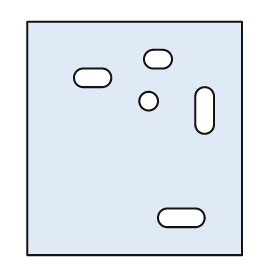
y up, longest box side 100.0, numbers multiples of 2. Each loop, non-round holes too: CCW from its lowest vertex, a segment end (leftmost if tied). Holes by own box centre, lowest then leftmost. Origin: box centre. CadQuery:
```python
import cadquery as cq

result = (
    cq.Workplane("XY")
    .moveTo(-46.0, -50.0)
    .lineTo(46.0, -50.0)
    .lineTo(46.0, 50.0)
    .lineTo(-46.0, 50.0)
    .close()
    .moveTo(14.0, -38.0)
    .lineTo(26.0, -38.0)
    .threePointArc((30.0, -34.0), (26.0, -30.0))
    .lineTo(14.0, -30.0)
    .threePointArc((10.0, -34.0), (14.0, -38.0))
    .close()
    .moveTo(26.0, 6.0)
    .threePointArc((30.0, 2.0), (34.0, 6.0))
    .lineTo(34.0, 18.0)
    .threePointArc((30.0, 22.0), (26.0, 18.0))
    .close()
    .moveTo(6.0, 16.0)
    .circle(4.0)
    .moveTo(-22.0, 22.0)
    .lineTo(-14.0, 22.0)
    .threePointArc((-10.0, 26.0), (-14.0, 30.0))
    .lineTo(-22.0, 30.0)
    .threePointArc((-26.0, 26.0), (-22.0, 22.0))
    .close()
    .moveTo(8.0, 30.0)
    .lineTo(12.0, 30.0)
    .threePointArc((16.0, 34.0), (12.0, 38.0))
    .lineTo(8.0, 38.0)
    .threePointArc((4.0, 34.0), (8.0, 30.0))
    .close()
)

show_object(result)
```